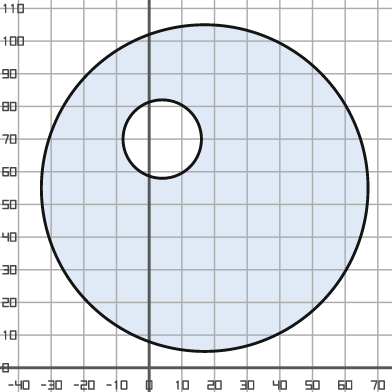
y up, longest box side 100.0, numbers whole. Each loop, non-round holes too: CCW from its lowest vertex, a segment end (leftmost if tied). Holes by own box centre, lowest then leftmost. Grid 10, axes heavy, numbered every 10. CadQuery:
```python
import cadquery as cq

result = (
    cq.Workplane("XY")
    .moveTo(17.0, 55.0)
    .circle(50.0)
    .moveTo(4.0, 70.0)
    .circle(12.0)
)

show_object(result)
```